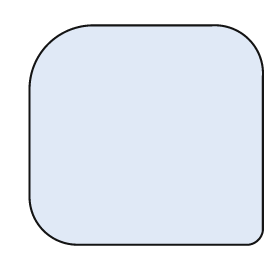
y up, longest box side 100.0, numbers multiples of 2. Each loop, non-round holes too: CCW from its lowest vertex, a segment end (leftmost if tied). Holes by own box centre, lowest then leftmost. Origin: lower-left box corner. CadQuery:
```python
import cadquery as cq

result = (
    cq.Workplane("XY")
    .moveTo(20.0, 0.0)
    .lineTo(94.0, 0.0)
    .threePointArc((98.0, 2.0), (100.0, 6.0))
    .lineTo(100.0, 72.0)
    .threePointArc((94.0, 88.0), (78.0, 94.0))
    .lineTo(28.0, 94.0)
    .threePointArc((8.0, 86.0), (0.0, 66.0))
    .lineTo(0.0, 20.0)
    .threePointArc((6.0, 6.0), (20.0, 0.0))
    .close()
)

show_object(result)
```